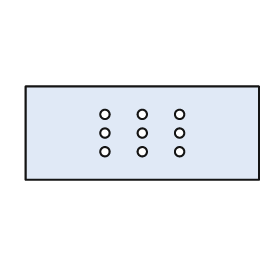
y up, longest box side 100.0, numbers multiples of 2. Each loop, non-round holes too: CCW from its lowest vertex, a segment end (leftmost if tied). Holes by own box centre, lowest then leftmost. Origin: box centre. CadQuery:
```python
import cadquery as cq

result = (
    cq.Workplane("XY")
    .moveTo(-50.0, -20.0)
    .lineTo(50.0, -20.0)
    .lineTo(50.0, 20.0)
    .lineTo(-50.0, 20.0)
    .close()
    .moveTo(-16.0, -8.0)
    .circle(2.0)
    .moveTo(0.0, -8.0)
    .circle(2.0)
    .moveTo(16.0, -8.0)
    .circle(2.0)
    .moveTo(-16.0, 0.0)
    .circle(2.0)
    .moveTo(0.0, 0.0)
    .circle(2.0)
    .moveTo(16.0, 0.0)
    .circle(2.0)
    .moveTo(-16.0, 8.0)
    .circle(2.0)
    .moveTo(0.0, 8.0)
    .circle(2.0)
    .moveTo(16.0, 8.0)
    .circle(2.0)
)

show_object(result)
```